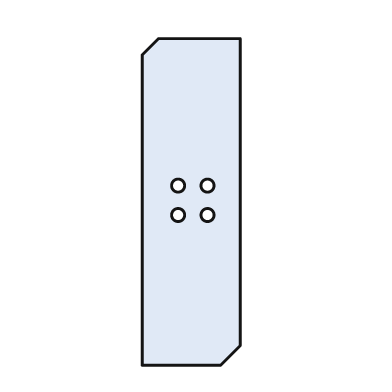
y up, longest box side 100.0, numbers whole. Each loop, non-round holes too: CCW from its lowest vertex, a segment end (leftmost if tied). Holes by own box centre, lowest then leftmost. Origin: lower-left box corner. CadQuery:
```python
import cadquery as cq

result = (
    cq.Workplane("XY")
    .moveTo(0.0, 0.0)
    .lineTo(24.0, 0.0)
    .lineTo(30.0, 6.0)
    .lineTo(30.0, 100.0)
    .lineTo(5.0, 100.0)
    .lineTo(0.0, 95.0)
    .close()
    .moveTo(11.0, 46.0)
    .circle(2.0)
    .moveTo(20.0, 46.0)
    .circle(2.0)
    .moveTo(11.0, 55.0)
    .circle(2.0)
    .moveTo(20.0, 55.0)
    .circle(2.0)
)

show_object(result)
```